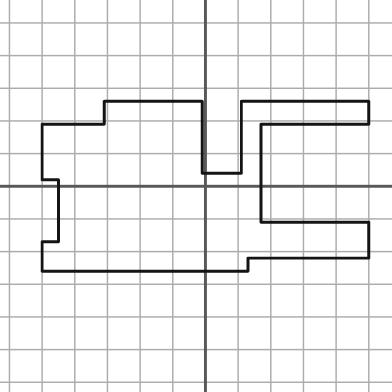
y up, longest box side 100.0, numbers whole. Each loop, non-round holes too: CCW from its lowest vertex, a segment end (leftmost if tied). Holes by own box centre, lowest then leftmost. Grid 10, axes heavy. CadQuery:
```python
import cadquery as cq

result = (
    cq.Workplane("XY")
    .moveTo(-50.0, -26.0)
    .lineTo(13.0, -26.0)
    .lineTo(13.0, -22.0)
    .lineTo(50.0, -22.0)
    .lineTo(50.0, -11.0)
    .lineTo(17.0, -11.0)
    .lineTo(17.0, 19.0)
    .lineTo(50.0, 19.0)
    .lineTo(50.0, 26.0)
    .lineTo(11.0, 26.0)
    .lineTo(11.0, 4.0)
    .lineTo(-1.0, 4.0)
    .lineTo(-1.0, 26.0)
    .lineTo(-31.0, 26.0)
    .lineTo(-31.0, 19.0)
    .lineTo(-50.0, 19.0)
    .lineTo(-50.0, 2.0)
    .lineTo(-45.0, 2.0)
    .lineTo(-45.0, -17.0)
    .lineTo(-50.0, -17.0)
    .close()
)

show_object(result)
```